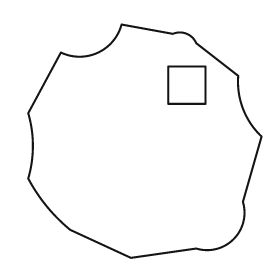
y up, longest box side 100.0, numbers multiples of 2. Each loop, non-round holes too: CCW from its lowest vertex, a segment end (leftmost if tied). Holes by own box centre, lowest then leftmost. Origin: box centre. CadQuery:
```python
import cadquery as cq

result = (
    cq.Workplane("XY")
    .moveTo(-6.0, -50.0)
    .lineTo(22.0, -46.0)
    .threePointArc((38.0, -42.0), (42.0, -26.0))
    .lineTo(50.0, 2.0)
    .threePointArc((42.0, 14.0), (40.0, 28.0))
    .lineTo(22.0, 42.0)
    .threePointArc((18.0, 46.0), (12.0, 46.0))
    .lineTo(-10.0, 50.0)
    .threePointArc((-20.0, 38.0), (-36.0, 38.0))
    .lineTo(-50.0, 12.0)
    .threePointArc((-48.0, -2.0), (-50.0, -16.0))
    .threePointArc((-42.0, -28.0), (-32.0, -38.0))
    .close()
    .moveTo(10.0, 16.0)
    .lineTo(26.0, 16.0)
    .lineTo(26.0, 32.0)
    .lineTo(10.0, 32.0)
    .close()
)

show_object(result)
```